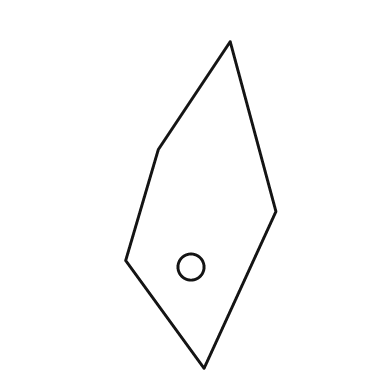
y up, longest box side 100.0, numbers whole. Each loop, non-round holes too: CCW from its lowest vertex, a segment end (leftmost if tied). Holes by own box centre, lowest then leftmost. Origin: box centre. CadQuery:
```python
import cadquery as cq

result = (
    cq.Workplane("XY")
    .moveTo(1.0, -50.0)
    .lineTo(23.0, -2.0)
    .lineTo(9.0, 50.0)
    .lineTo(-13.0, 17.0)
    .lineTo(-23.0, -17.0)
    .close()
    .moveTo(-3.0, -19.0)
    .circle(4.0)
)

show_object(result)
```